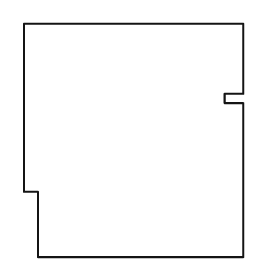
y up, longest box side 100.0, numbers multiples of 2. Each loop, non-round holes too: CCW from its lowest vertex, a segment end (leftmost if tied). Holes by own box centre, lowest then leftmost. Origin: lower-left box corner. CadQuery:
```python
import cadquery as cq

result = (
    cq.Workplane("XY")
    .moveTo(6.0, 0.0)
    .lineTo(94.0, 0.0)
    .lineTo(94.0, 66.0)
    .lineTo(86.0, 66.0)
    .lineTo(86.0, 70.0)
    .lineTo(94.0, 70.0)
    .lineTo(94.0, 100.0)
    .lineTo(0.0, 100.0)
    .lineTo(0.0, 28.0)
    .lineTo(6.0, 28.0)
    .close()
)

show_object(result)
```